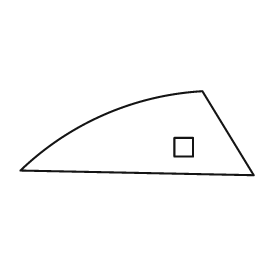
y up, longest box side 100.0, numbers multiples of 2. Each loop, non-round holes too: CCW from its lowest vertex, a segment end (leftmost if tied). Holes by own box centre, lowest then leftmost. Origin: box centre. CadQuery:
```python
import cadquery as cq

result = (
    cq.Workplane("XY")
    .moveTo(50.0, -18.0)
    .lineTo(28.0, 18.0)
    .threePointArc((-14.0, 8.0), (-50.0, -16.0))
    .close()
    .moveTo(16.0, -10.0)
    .lineTo(24.0, -10.0)
    .lineTo(24.0, -2.0)
    .lineTo(16.0, -2.0)
    .close()
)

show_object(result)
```